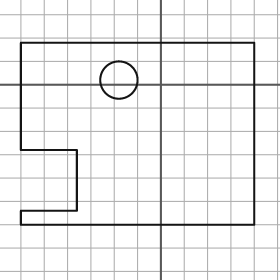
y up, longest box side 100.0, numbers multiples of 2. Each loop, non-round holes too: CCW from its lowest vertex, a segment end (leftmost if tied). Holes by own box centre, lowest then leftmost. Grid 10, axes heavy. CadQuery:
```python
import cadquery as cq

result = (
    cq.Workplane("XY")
    .moveTo(-60.0, -60.0)
    .lineTo(40.0, -60.0)
    .lineTo(40.0, 18.0)
    .lineTo(-60.0, 18.0)
    .lineTo(-60.0, -28.0)
    .lineTo(-36.0, -28.0)
    .lineTo(-36.0, -54.0)
    .lineTo(-60.0, -54.0)
    .close()
    .moveTo(-18.0, 2.0)
    .circle(8.0)
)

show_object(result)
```